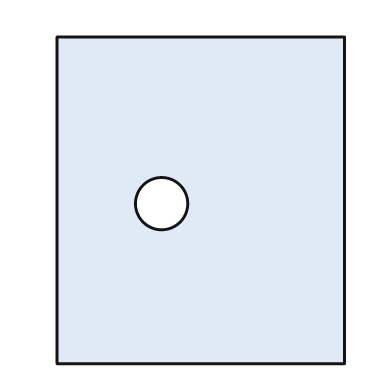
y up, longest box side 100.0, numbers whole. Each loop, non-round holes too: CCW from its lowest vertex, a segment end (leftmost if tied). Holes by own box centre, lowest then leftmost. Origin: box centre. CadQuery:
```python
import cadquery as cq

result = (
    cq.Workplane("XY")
    .moveTo(-44.0, -50.0)
    .lineTo(44.0, -50.0)
    .lineTo(44.0, 50.0)
    .lineTo(-44.0, 50.0)
    .close()
    .moveTo(-12.0, -1.0)
    .circle(8.0)
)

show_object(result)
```